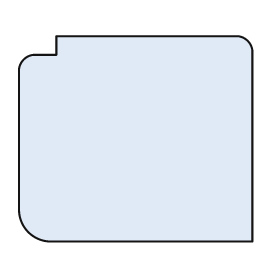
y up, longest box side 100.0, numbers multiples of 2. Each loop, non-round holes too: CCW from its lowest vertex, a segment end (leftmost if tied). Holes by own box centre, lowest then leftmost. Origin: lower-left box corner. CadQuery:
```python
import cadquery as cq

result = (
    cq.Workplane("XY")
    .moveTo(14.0, 0.0)
    .lineTo(100.0, 0.0)
    .lineTo(100.0, 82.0)
    .threePointArc((98.0, 86.0), (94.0, 88.0))
    .lineTo(16.0, 88.0)
    .lineTo(16.0, 80.0)
    .lineTo(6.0, 80.0)
    .threePointArc((2.0, 78.0), (0.0, 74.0))
    .lineTo(0.0, 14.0)
    .threePointArc((4.0, 4.0), (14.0, 0.0))
    .close()
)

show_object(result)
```